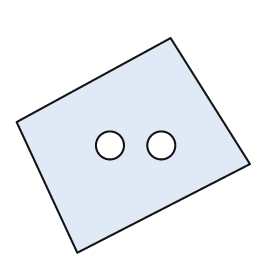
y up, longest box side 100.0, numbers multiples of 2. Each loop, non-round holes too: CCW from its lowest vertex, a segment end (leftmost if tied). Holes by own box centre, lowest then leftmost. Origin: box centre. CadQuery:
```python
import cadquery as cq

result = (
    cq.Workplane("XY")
    .moveTo(-24.0, -46.0)
    .lineTo(50.0, -8.0)
    .lineTo(16.0, 46.0)
    .lineTo(-50.0, 10.0)
    .close()
    .moveTo(-10.0, 0.0)
    .circle(6.0)
    .moveTo(12.0, 0.0)
    .circle(6.0)
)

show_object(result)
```